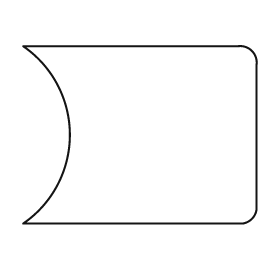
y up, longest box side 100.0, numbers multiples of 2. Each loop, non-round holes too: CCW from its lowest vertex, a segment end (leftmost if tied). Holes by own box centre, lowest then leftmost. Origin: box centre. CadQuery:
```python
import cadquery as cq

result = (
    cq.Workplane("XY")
    .moveTo(-50.0, -38.0)
    .lineTo(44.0, -38.0)
    .threePointArc((48.0, -36.0), (50.0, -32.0))
    .lineTo(50.0, 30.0)
    .threePointArc((48.0, 36.0), (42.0, 38.0))
    .lineTo(-50.0, 38.0)
    .threePointArc((-30.0, 0.0), (-50.0, -38.0))
    .close()
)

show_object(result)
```